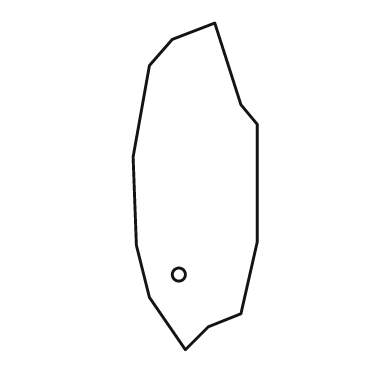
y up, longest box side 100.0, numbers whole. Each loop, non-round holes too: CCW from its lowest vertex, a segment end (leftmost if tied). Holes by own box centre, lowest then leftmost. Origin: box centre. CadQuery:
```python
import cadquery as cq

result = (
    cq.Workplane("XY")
    .moveTo(-3.0, -50.0)
    .lineTo(4.0, -43.0)
    .lineTo(14.0, -39.0)
    .lineTo(19.0, -17.0)
    .lineTo(19.0, 19.0)
    .lineTo(14.0, 25.0)
    .lineTo(6.0, 50.0)
    .lineTo(-7.0, 45.0)
    .lineTo(-14.0, 37.0)
    .lineTo(-19.0, 9.0)
    .lineTo(-18.0, -18.0)
    .lineTo(-14.0, -34.0)
    .close()
    .moveTo(-5.0, -27.0)
    .circle(2.0)
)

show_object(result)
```